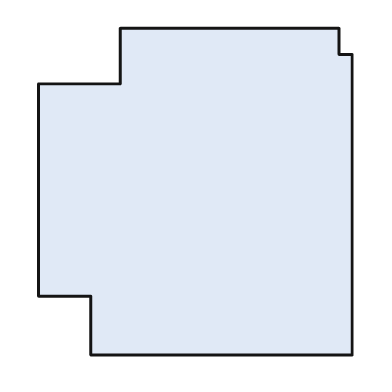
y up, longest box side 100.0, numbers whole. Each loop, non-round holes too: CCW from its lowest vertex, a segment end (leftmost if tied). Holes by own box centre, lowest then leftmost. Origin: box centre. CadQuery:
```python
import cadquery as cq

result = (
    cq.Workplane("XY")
    .moveTo(-32.0, -50.0)
    .lineTo(48.0, -50.0)
    .lineTo(48.0, 42.0)
    .lineTo(44.0, 42.0)
    .lineTo(44.0, 50.0)
    .lineTo(-23.0, 50.0)
    .lineTo(-23.0, 33.0)
    .lineTo(-48.0, 33.0)
    .lineTo(-48.0, -32.0)
    .lineTo(-32.0, -32.0)
    .close()
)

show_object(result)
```